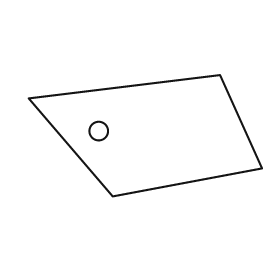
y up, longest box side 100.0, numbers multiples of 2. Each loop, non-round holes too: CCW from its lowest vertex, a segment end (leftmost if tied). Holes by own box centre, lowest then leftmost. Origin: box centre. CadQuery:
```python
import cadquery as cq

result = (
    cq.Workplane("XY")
    .moveTo(-14.0, -26.0)
    .lineTo(50.0, -14.0)
    .lineTo(32.0, 26.0)
    .lineTo(-50.0, 16.0)
    .close()
    .moveTo(-20.0, 2.0)
    .circle(4.0)
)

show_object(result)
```